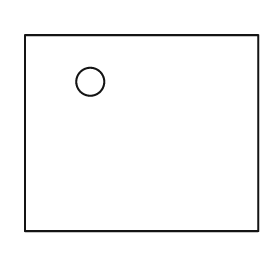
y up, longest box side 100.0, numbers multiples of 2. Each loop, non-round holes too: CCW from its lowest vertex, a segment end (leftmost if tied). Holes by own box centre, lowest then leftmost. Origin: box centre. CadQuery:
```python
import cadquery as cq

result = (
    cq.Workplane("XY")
    .moveTo(-50.0, -42.0)
    .lineTo(50.0, -42.0)
    .lineTo(50.0, 42.0)
    .lineTo(-50.0, 42.0)
    .close()
    .moveTo(-22.0, 22.0)
    .circle(6.0)
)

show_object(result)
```